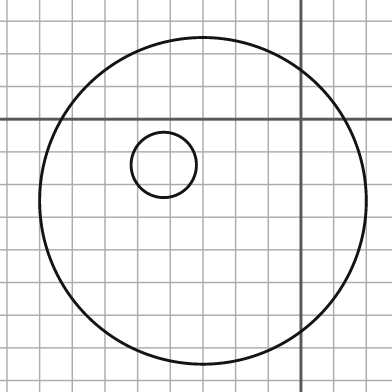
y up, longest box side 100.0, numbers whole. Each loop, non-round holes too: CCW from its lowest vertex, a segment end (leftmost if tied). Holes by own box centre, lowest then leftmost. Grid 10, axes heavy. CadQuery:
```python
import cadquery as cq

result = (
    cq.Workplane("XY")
    .moveTo(-30.0, -25.0)
    .circle(50.0)
    .moveTo(-42.0, -14.0)
    .circle(10.0)
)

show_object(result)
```